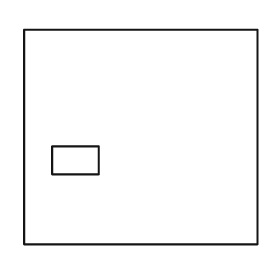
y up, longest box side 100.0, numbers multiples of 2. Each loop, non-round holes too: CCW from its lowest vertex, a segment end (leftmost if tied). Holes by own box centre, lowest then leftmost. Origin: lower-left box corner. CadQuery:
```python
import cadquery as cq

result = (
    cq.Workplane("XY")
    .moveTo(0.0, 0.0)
    .lineTo(100.0, 0.0)
    .lineTo(100.0, 92.0)
    .lineTo(0.0, 92.0)
    .close()
    .moveTo(12.0, 30.0)
    .lineTo(32.0, 30.0)
    .lineTo(32.0, 42.0)
    .lineTo(12.0, 42.0)
    .close()
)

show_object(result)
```